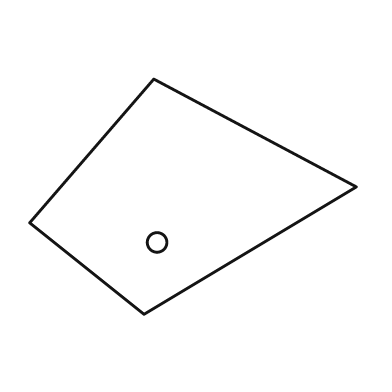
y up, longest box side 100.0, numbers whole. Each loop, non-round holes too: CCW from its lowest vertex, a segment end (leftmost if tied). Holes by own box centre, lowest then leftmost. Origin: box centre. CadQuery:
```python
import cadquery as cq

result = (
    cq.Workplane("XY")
    .moveTo(-15.0, -36.0)
    .lineTo(50.0, 3.0)
    .lineTo(-12.0, 36.0)
    .lineTo(-50.0, -8.0)
    .close()
    .moveTo(-11.0, -14.0)
    .circle(3.0)
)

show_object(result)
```